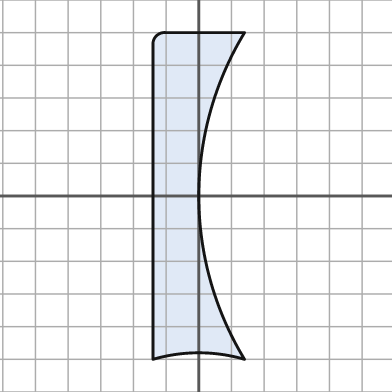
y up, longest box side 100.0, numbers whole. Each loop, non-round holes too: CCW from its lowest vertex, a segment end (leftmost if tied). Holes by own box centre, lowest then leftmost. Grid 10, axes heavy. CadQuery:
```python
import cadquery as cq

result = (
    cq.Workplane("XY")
    .moveTo(-14.0, -50.0)
    .threePointArc((0.0, -48.0), (14.0, -50.0))
    .threePointArc((0.0, 0.0), (14.0, 50.0))
    .lineTo(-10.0, 50.0)
    .threePointArc((-13.0, 49.0), (-14.0, 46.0))
    .close()
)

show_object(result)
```